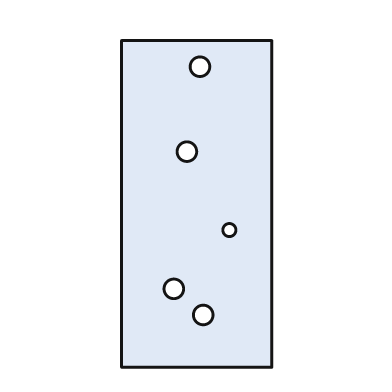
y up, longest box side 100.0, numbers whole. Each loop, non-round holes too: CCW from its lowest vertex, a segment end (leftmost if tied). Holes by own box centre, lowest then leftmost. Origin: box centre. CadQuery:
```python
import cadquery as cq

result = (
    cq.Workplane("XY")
    .moveTo(-23.0, -50.0)
    .lineTo(23.0, -50.0)
    .lineTo(23.0, 50.0)
    .lineTo(-23.0, 50.0)
    .close()
    .moveTo(2.0, -34.0)
    .circle(3.0)
    .moveTo(-7.0, -26.0)
    .circle(3.0)
    .moveTo(10.0, -8.0)
    .circle(2.0)
    .moveTo(-3.0, 16.0)
    .circle(3.0)
    .moveTo(1.0, 42.0)
    .circle(3.0)
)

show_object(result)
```